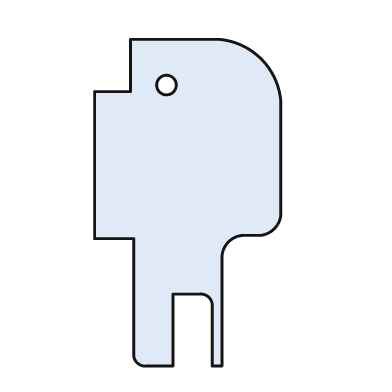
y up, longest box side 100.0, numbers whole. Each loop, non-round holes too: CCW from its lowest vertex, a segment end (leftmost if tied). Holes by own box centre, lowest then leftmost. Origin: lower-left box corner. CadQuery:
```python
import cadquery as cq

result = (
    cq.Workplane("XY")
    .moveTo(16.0, 0.0)
    .lineTo(24.0, 0.0)
    .lineTo(24.0, 22.0)
    .lineTo(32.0, 22.0)
    .threePointArc((35.0, 21.0), (36.0, 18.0))
    .lineTo(36.0, 0.0)
    .lineTo(39.0, 0.0)
    .lineTo(39.0, 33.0)
    .threePointArc((41.0, 38.0), (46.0, 40.0))
    .lineTo(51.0, 40.0)
    .threePointArc((55.0, 42.0), (57.0, 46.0))
    .lineTo(57.0, 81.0)
    .threePointArc((51.0, 94.0), (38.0, 100.0))
    .lineTo(11.0, 100.0)
    .lineTo(11.0, 84.0)
    .lineTo(0.0, 84.0)
    .lineTo(0.0, 39.0)
    .lineTo(12.0, 39.0)
    .lineTo(12.0, 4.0)
    .threePointArc((13.0, 1.0), (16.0, 0.0))
    .close()
    .moveTo(22.0, 86.0)
    .circle(3.0)
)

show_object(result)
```